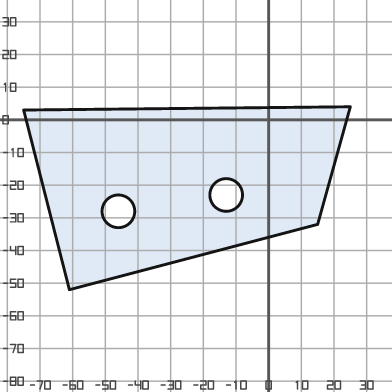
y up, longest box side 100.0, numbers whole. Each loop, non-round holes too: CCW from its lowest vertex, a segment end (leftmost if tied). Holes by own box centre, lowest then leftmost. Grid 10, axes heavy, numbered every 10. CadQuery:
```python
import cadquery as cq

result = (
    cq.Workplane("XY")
    .moveTo(-61.0, -52.0)
    .lineTo(15.0, -32.0)
    .lineTo(25.0, 4.0)
    .lineTo(-75.0, 3.0)
    .close()
    .moveTo(-46.0, -28.0)
    .circle(5.0)
    .moveTo(-13.0, -23.0)
    .circle(5.0)
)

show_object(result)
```